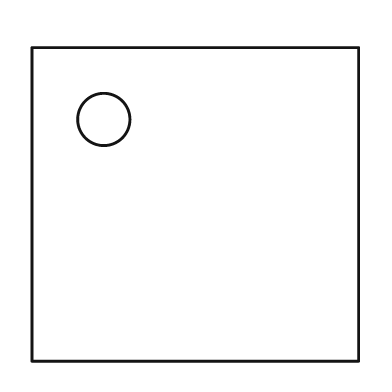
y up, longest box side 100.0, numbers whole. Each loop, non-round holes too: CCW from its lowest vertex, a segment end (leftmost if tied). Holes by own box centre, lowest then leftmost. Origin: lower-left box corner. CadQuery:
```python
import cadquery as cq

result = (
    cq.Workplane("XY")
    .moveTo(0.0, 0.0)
    .lineTo(100.0, 0.0)
    .lineTo(100.0, 96.0)
    .lineTo(0.0, 96.0)
    .close()
    .moveTo(22.0, 74.0)
    .circle(8.0)
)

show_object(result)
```